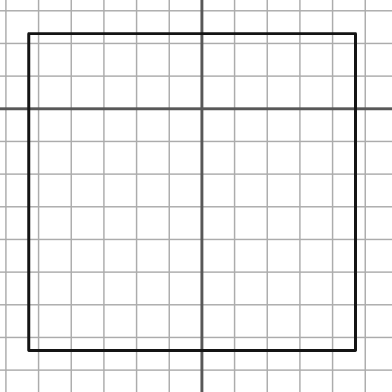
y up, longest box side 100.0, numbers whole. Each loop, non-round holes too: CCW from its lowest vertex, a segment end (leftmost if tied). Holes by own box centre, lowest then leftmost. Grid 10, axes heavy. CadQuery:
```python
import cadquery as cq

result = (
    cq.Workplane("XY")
    .moveTo(-53.0, -74.0)
    .lineTo(47.0, -74.0)
    .lineTo(47.0, 23.0)
    .lineTo(-53.0, 23.0)
    .close()
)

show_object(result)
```